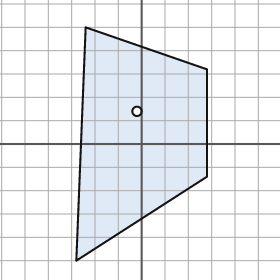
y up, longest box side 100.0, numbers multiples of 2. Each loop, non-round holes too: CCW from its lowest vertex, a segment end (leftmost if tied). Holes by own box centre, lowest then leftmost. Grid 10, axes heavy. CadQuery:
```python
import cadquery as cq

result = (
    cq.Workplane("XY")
    .moveTo(-28.0, -50.0)
    .lineTo(28.0, -14.0)
    .lineTo(28.0, 32.0)
    .lineTo(-24.0, 50.0)
    .close()
    .moveTo(-2.0, 14.0)
    .circle(2.0)
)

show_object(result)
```